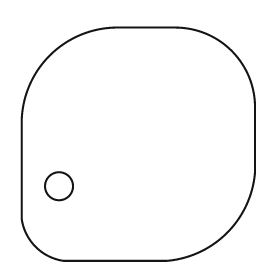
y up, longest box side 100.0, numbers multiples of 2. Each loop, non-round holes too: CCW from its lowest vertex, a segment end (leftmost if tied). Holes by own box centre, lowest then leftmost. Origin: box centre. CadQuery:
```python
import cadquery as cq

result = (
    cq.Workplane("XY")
    .moveTo(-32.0, -50.0)
    .lineTo(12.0, -50.0)
    .threePointArc((38.0, -38.0), (50.0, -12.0))
    .lineTo(50.0, 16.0)
    .threePointArc((40.0, 40.0), (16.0, 50.0))
    .lineTo(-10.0, 50.0)
    .threePointArc((-38.0, 38.0), (-50.0, 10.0))
    .lineTo(-50.0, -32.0)
    .threePointArc((-44.0, -44.0), (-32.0, -50.0))
    .close()
    .moveTo(-34.0, -18.0)
    .circle(6.0)
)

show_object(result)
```